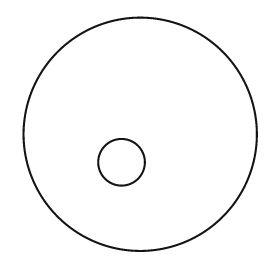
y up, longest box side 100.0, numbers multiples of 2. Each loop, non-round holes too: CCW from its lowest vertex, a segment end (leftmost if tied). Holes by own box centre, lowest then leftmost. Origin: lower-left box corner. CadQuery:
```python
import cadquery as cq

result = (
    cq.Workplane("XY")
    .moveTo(50.0, 50.0)
    .circle(50.0)
    .moveTo(42.0, 38.0)
    .circle(10.0)
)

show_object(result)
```